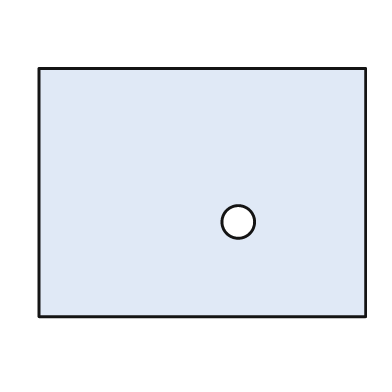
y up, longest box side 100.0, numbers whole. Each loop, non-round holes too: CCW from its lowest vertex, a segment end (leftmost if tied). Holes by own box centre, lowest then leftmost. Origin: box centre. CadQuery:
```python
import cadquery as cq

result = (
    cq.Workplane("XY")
    .moveTo(-50.0, -38.0)
    .lineTo(50.0, -38.0)
    .lineTo(50.0, 38.0)
    .lineTo(-50.0, 38.0)
    .close()
    .moveTo(11.0, -9.0)
    .circle(5.0)
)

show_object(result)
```